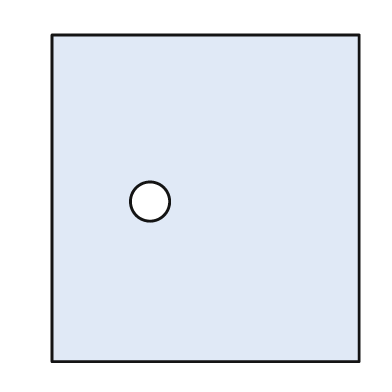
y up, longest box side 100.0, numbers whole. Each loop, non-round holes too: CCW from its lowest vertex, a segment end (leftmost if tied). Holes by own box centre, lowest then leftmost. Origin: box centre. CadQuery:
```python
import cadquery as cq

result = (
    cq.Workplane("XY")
    .moveTo(-47.0, -50.0)
    .lineTo(47.0, -50.0)
    .lineTo(47.0, 50.0)
    .lineTo(-47.0, 50.0)
    .close()
    .moveTo(-17.0, -1.0)
    .circle(6.0)
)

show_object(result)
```